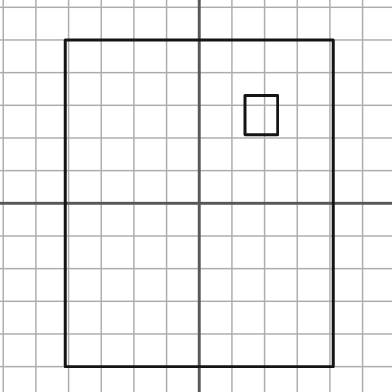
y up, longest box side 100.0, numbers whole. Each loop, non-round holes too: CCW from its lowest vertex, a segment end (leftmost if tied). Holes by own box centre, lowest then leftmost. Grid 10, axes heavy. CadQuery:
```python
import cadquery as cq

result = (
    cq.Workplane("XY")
    .moveTo(-41.0, -50.0)
    .lineTo(41.0, -50.0)
    .lineTo(41.0, 50.0)
    .lineTo(-41.0, 50.0)
    .close()
    .moveTo(14.0, 21.0)
    .lineTo(24.0, 21.0)
    .lineTo(24.0, 33.0)
    .lineTo(14.0, 33.0)
    .close()
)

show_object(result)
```